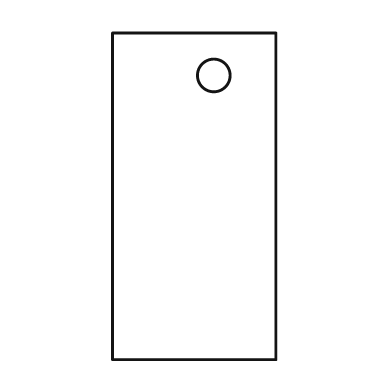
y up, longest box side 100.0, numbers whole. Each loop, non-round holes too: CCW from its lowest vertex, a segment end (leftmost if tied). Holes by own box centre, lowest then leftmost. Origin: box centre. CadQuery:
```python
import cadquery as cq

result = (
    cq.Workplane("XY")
    .moveTo(-25.0, -50.0)
    .lineTo(25.0, -50.0)
    .lineTo(25.0, 50.0)
    .lineTo(-25.0, 50.0)
    .close()
    .moveTo(6.0, 37.0)
    .circle(5.0)
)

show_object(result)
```